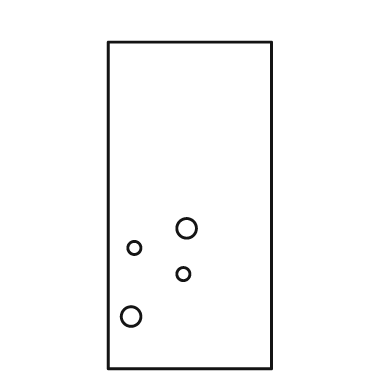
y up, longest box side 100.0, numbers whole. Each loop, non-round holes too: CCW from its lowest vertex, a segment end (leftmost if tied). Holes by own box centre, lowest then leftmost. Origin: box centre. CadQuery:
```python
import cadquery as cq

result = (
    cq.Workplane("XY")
    .moveTo(-25.0, -50.0)
    .lineTo(25.0, -50.0)
    .lineTo(25.0, 50.0)
    .lineTo(-25.0, 50.0)
    .close()
    .moveTo(-18.0, -34.0)
    .circle(3.0)
    .moveTo(-2.0, -21.0)
    .circle(2.0)
    .moveTo(-17.0, -13.0)
    .circle(2.0)
    .moveTo(-1.0, -7.0)
    .circle(3.0)
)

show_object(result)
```